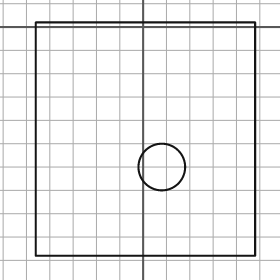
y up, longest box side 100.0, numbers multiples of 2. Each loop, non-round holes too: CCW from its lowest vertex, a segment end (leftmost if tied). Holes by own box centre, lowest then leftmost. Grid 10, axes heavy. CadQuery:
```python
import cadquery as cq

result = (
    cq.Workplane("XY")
    .moveTo(-46.0, -98.0)
    .lineTo(48.0, -98.0)
    .lineTo(48.0, 2.0)
    .lineTo(-46.0, 2.0)
    .close()
    .moveTo(8.0, -60.0)
    .circle(10.0)
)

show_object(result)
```